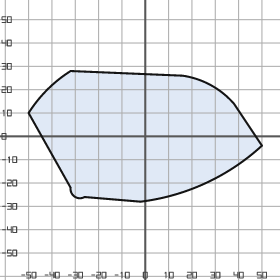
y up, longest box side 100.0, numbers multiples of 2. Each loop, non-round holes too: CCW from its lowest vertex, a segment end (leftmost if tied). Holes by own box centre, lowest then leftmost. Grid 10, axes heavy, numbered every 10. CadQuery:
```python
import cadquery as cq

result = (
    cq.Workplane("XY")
    .moveTo(-2.0, -28.0)
    .threePointArc((26.0, -20.0), (50.0, -4.0))
    .lineTo(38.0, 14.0)
    .threePointArc((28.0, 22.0), (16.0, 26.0))
    .lineTo(-32.0, 28.0)
    .threePointArc((-42.0, 20.0), (-50.0, 10.0))
    .lineTo(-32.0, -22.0)
    .threePointArc((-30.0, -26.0), (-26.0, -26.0))
    .close()
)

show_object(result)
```